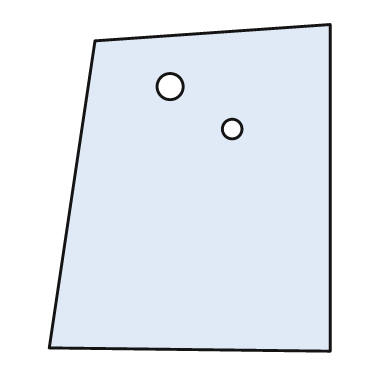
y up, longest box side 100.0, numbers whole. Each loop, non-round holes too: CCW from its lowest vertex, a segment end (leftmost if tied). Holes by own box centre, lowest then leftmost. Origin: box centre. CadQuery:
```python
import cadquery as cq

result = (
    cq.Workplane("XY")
    .moveTo(43.0, -50.0)
    .lineTo(43.0, 50.0)
    .lineTo(-29.0, 45.0)
    .lineTo(-43.0, -49.0)
    .close()
    .moveTo(13.0, 18.0)
    .circle(3.0)
    .moveTo(-6.0, 31.0)
    .circle(4.0)
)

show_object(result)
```